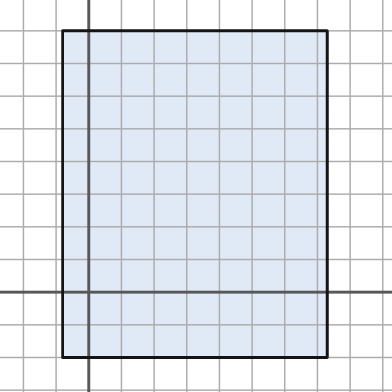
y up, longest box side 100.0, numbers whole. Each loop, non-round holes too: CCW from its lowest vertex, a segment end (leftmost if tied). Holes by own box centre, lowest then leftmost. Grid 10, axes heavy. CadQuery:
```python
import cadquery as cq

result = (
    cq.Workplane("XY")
    .moveTo(-8.0, -20.0)
    .lineTo(73.0, -20.0)
    .lineTo(73.0, 80.0)
    .lineTo(-8.0, 80.0)
    .close()
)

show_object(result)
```